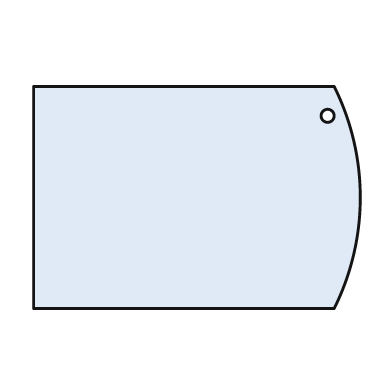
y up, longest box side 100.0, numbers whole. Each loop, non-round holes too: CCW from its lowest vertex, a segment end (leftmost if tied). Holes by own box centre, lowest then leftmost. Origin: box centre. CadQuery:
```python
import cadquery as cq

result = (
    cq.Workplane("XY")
    .moveTo(-50.0, -34.0)
    .lineTo(42.0, -34.0)
    .threePointArc((50.0, 0.0), (42.0, 34.0))
    .lineTo(-50.0, 34.0)
    .close()
    .moveTo(40.0, 25.0)
    .circle(2.0)
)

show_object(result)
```